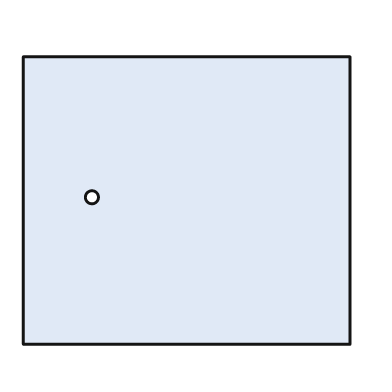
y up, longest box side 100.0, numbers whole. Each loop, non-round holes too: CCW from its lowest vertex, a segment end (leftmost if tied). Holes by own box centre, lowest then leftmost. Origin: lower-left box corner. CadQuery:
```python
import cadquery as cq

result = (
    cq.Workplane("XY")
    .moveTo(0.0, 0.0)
    .lineTo(100.0, 0.0)
    .lineTo(100.0, 88.0)
    .lineTo(0.0, 88.0)
    .close()
    .moveTo(21.0, 45.0)
    .circle(2.0)
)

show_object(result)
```